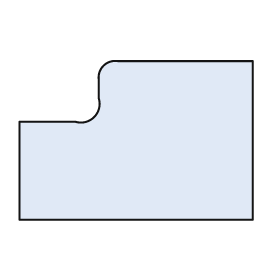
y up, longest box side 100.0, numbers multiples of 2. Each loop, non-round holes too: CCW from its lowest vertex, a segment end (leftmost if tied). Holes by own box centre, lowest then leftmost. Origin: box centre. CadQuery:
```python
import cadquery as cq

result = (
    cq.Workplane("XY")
    .moveTo(-50.0, -34.0)
    .lineTo(50.0, -34.0)
    .lineTo(50.0, 34.0)
    .lineTo(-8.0, 34.0)
    .threePointArc((-14.0, 32.0), (-16.0, 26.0))
    .lineTo(-16.0, 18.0)
    .threePointArc((-18.0, 10.0), (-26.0, 8.0))
    .lineTo(-50.0, 8.0)
    .close()
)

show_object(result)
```